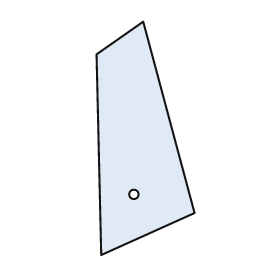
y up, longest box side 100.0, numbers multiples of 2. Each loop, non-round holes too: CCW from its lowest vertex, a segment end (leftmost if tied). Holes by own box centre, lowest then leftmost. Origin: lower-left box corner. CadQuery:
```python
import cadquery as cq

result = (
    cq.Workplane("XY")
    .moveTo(2.0, 0.0)
    .lineTo(42.0, 18.0)
    .lineTo(20.0, 100.0)
    .lineTo(0.0, 86.0)
    .close()
    .moveTo(16.0, 26.0)
    .circle(2.0)
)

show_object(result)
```